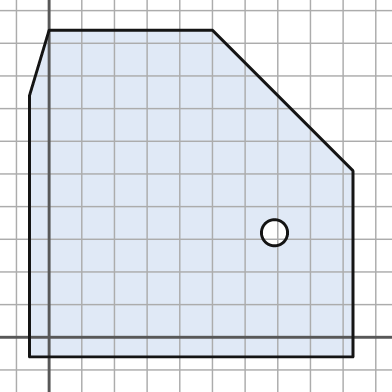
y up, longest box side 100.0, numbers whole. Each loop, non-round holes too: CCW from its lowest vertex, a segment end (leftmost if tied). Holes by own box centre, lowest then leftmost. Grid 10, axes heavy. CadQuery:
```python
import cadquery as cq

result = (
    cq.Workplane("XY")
    .moveTo(-6.0, -6.0)
    .lineTo(93.0, -6.0)
    .lineTo(93.0, 51.0)
    .lineTo(50.0, 94.0)
    .lineTo(0.0, 94.0)
    .lineTo(-6.0, 74.0)
    .close()
    .moveTo(69.0, 32.0)
    .circle(4.0)
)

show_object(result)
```